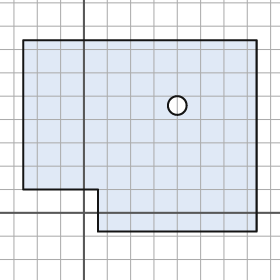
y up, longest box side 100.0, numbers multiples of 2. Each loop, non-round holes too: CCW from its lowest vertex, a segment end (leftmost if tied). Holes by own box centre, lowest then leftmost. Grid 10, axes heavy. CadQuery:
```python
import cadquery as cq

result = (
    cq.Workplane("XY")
    .moveTo(6.0, -8.0)
    .lineTo(74.0, -8.0)
    .lineTo(74.0, 74.0)
    .lineTo(-26.0, 74.0)
    .lineTo(-26.0, 10.0)
    .lineTo(6.0, 10.0)
    .close()
    .moveTo(40.0, 46.0)
    .circle(4.0)
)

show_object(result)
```